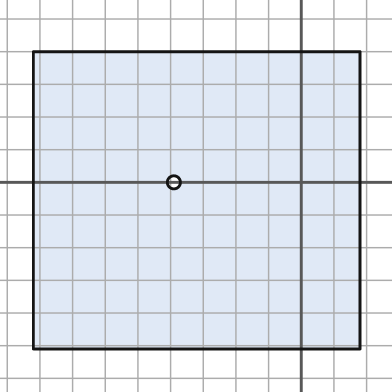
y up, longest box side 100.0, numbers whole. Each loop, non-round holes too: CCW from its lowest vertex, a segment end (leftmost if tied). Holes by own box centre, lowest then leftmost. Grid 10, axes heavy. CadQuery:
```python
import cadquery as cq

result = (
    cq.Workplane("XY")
    .moveTo(-82.0, -51.0)
    .lineTo(18.0, -51.0)
    .lineTo(18.0, 40.0)
    .lineTo(-82.0, 40.0)
    .close()
    .moveTo(-39.0, 0.0)
    .circle(2.0)
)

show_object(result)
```